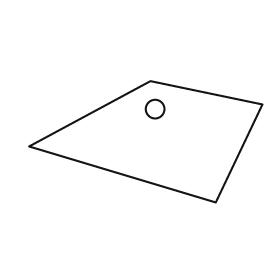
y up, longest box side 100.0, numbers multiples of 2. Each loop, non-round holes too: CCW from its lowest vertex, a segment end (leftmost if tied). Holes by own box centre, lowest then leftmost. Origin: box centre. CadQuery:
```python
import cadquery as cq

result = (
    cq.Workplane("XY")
    .moveTo(30.0, -26.0)
    .lineTo(50.0, 16.0)
    .lineTo(2.0, 26.0)
    .lineTo(-50.0, -2.0)
    .close()
    .moveTo(4.0, 14.0)
    .circle(4.0)
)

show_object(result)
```